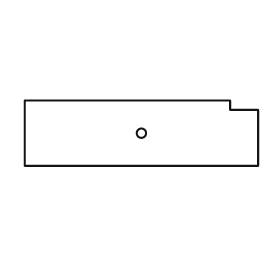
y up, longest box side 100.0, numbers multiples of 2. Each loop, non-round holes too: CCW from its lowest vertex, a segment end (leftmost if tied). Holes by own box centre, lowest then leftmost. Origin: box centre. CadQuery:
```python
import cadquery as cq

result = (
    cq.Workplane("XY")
    .moveTo(-50.0, -14.0)
    .lineTo(50.0, -14.0)
    .lineTo(50.0, 10.0)
    .lineTo(38.0, 10.0)
    .lineTo(38.0, 14.0)
    .lineTo(-50.0, 14.0)
    .close()
    .moveTo(0.0, 0.0)
    .circle(2.0)
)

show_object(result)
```